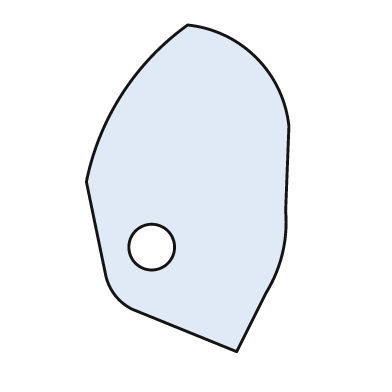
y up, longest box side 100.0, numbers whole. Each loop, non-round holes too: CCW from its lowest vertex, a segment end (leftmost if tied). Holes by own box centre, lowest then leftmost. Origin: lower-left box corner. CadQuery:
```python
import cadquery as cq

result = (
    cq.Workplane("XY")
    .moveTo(46.0, 0.0)
    .lineTo(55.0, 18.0)
    .threePointArc((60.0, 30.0), (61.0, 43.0))
    .lineTo(62.0, 69.0)
    .threePointArc((52.0, 90.0), (31.0, 100.0))
    .threePointArc((11.0, 79.0), (0.0, 52.0))
    .lineTo(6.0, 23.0)
    .threePointArc((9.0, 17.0), (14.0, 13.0))
    .close()
    .moveTo(20.0, 32.0)
    .circle(7.0)
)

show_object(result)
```